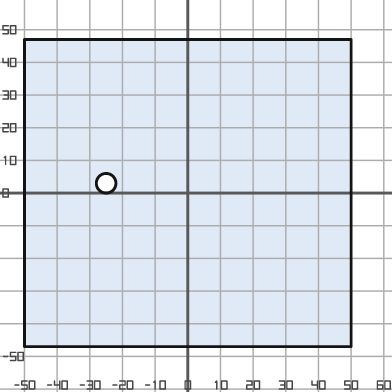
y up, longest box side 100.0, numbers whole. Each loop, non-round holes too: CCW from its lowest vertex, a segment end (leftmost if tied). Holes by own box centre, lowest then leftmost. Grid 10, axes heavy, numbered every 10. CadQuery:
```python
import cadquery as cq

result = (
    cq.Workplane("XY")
    .moveTo(-50.0, -47.0)
    .lineTo(50.0, -47.0)
    .lineTo(50.0, 47.0)
    .lineTo(-50.0, 47.0)
    .close()
    .moveTo(-25.0, 3.0)
    .circle(3.0)
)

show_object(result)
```